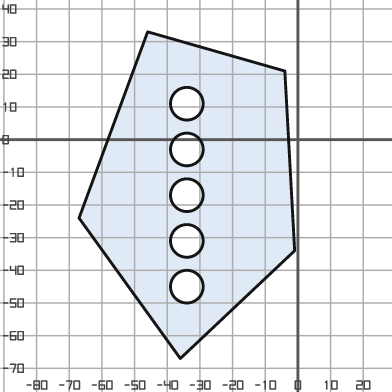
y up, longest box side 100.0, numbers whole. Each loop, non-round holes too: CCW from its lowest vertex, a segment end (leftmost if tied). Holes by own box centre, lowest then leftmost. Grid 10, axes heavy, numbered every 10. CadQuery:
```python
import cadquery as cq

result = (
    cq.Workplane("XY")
    .moveTo(-36.0, -67.0)
    .lineTo(-1.0, -34.0)
    .lineTo(-4.0, 21.0)
    .lineTo(-46.0, 33.0)
    .lineTo(-67.0, -24.0)
    .close()
    .moveTo(-34.0, -45.0)
    .circle(5.0)
    .moveTo(-34.0, -31.0)
    .circle(5.0)
    .moveTo(-34.0, -17.0)
    .circle(5.0)
    .moveTo(-34.0, -3.0)
    .circle(5.0)
    .moveTo(-34.0, 11.0)
    .circle(5.0)
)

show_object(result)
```